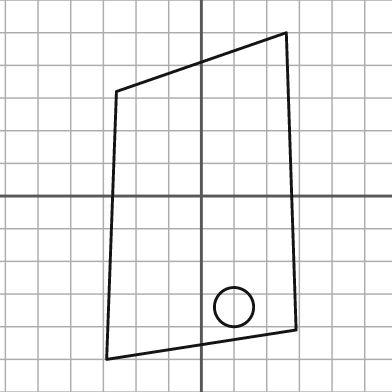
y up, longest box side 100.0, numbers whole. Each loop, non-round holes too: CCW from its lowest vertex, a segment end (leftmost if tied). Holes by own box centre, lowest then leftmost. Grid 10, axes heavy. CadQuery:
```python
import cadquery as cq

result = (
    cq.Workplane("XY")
    .moveTo(-29.0, -50.0)
    .lineTo(29.0, -41.0)
    .lineTo(26.0, 50.0)
    .lineTo(-26.0, 32.0)
    .close()
    .moveTo(10.0, -34.0)
    .circle(6.0)
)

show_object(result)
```